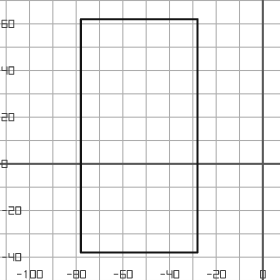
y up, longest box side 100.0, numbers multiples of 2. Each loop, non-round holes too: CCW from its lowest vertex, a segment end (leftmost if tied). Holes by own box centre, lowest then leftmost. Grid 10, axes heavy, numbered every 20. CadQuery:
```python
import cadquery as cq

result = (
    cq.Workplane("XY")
    .moveTo(-78.0, -38.0)
    .lineTo(-28.0, -38.0)
    .lineTo(-28.0, 62.0)
    .lineTo(-78.0, 62.0)
    .close()
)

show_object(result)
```